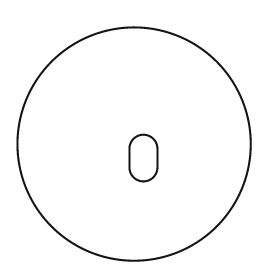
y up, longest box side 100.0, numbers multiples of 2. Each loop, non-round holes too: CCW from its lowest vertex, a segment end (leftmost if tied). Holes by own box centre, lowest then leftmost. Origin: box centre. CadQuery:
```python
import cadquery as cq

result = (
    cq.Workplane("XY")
    .moveTo(0.0, 0.0)
    .circle(50.0)
    .moveTo(-2.0, -10.0)
    .threePointArc((4.0, -16.0), (10.0, -10.0))
    .lineTo(10.0, -2.0)
    .threePointArc((4.0, 4.0), (-2.0, -2.0))
    .close()
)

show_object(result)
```